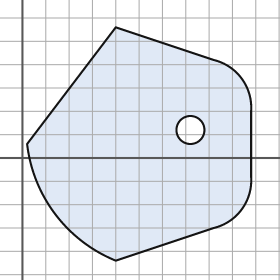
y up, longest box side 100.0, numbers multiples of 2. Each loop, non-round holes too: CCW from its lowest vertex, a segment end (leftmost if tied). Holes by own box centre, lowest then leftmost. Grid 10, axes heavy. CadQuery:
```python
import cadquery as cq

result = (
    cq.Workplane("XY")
    .moveTo(40.0, -44.0)
    .lineTo(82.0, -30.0)
    .threePointArc((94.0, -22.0), (98.0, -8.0))
    .lineTo(98.0, 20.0)
    .threePointArc((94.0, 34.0), (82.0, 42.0))
    .lineTo(40.0, 56.0)
    .lineTo(2.0, 6.0)
    .threePointArc((14.0, -24.0), (40.0, -44.0))
    .close()
    .moveTo(72.0, 12.0)
    .circle(6.0)
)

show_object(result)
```